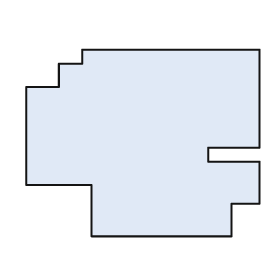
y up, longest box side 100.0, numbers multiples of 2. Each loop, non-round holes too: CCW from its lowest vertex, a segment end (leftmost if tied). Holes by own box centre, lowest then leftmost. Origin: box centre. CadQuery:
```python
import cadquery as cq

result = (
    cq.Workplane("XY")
    .moveTo(-22.0, -40.0)
    .lineTo(38.0, -40.0)
    .lineTo(38.0, -26.0)
    .lineTo(50.0, -26.0)
    .lineTo(50.0, -8.0)
    .lineTo(28.0, -8.0)
    .lineTo(28.0, -2.0)
    .lineTo(50.0, -2.0)
    .lineTo(50.0, 40.0)
    .lineTo(-26.0, 40.0)
    .lineTo(-26.0, 34.0)
    .lineTo(-36.0, 34.0)
    .lineTo(-36.0, 24.0)
    .lineTo(-50.0, 24.0)
    .lineTo(-50.0, -18.0)
    .lineTo(-22.0, -18.0)
    .close()
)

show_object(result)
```